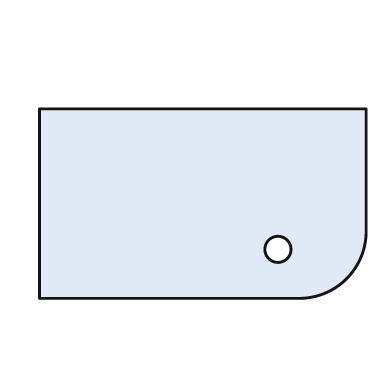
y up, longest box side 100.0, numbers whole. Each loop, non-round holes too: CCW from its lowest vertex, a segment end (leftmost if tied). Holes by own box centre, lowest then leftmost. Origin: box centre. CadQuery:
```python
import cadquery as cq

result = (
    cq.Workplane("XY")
    .moveTo(-50.0, -29.0)
    .lineTo(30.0, -29.0)
    .threePointArc((44.0, -23.0), (50.0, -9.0))
    .lineTo(50.0, 29.0)
    .lineTo(-50.0, 29.0)
    .close()
    .moveTo(23.0, -14.0)
    .circle(4.0)
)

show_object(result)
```